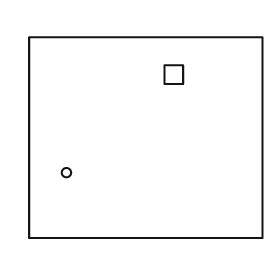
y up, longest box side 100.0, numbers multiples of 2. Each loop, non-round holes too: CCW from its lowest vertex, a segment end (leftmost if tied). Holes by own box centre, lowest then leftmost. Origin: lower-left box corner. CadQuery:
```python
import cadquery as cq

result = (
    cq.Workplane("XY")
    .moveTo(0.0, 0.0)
    .lineTo(100.0, 0.0)
    .lineTo(100.0, 86.0)
    .lineTo(0.0, 86.0)
    .close()
    .moveTo(16.0, 28.0)
    .circle(2.0)
    .moveTo(58.0, 66.0)
    .lineTo(66.0, 66.0)
    .lineTo(66.0, 74.0)
    .lineTo(58.0, 74.0)
    .close()
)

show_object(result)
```